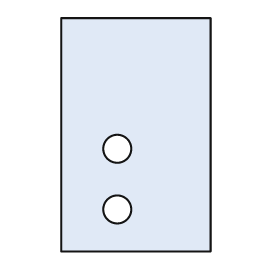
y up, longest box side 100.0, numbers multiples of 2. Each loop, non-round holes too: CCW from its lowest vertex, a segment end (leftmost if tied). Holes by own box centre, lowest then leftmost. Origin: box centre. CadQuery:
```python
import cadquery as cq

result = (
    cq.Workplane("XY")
    .moveTo(-32.0, -50.0)
    .lineTo(32.0, -50.0)
    .lineTo(32.0, 50.0)
    .lineTo(-32.0, 50.0)
    .close()
    .moveTo(-8.0, -32.0)
    .circle(6.0)
    .moveTo(-8.0, -6.0)
    .circle(6.0)
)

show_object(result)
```